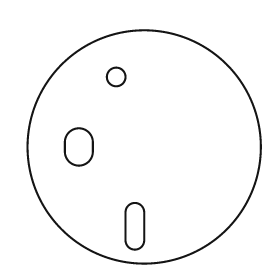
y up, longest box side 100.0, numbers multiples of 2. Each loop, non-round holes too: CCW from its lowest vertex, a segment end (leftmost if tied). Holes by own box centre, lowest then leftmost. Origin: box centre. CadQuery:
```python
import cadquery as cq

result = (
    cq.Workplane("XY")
    .moveTo(0.0, 0.0)
    .circle(50.0)
    .moveTo(-8.0, -40.0)
    .threePointArc((-4.0, -44.0), (0.0, -40.0))
    .lineTo(0.0, -28.0)
    .threePointArc((-4.0, -24.0), (-8.0, -28.0))
    .close()
    .moveTo(-34.0, -2.0)
    .threePointArc((-28.0, -8.0), (-22.0, -2.0))
    .lineTo(-22.0, 2.0)
    .threePointArc((-28.0, 8.0), (-34.0, 2.0))
    .close()
    .moveTo(-12.0, 30.0)
    .circle(4.0)
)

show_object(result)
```